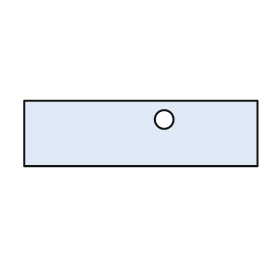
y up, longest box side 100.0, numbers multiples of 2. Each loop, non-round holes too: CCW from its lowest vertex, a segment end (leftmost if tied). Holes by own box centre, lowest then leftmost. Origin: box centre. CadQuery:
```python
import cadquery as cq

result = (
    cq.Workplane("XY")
    .moveTo(-50.0, -14.0)
    .lineTo(50.0, -14.0)
    .lineTo(50.0, 14.0)
    .lineTo(-50.0, 14.0)
    .close()
    .moveTo(10.0, 6.0)
    .circle(4.0)
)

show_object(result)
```